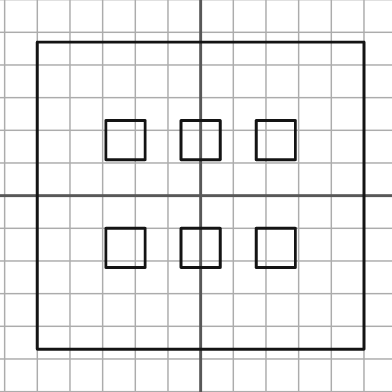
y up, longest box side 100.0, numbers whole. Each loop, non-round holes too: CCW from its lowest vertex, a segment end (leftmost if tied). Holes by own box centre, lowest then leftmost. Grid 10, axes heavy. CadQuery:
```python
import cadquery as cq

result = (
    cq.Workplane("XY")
    .moveTo(-50.0, -47.0)
    .lineTo(50.0, -47.0)
    .lineTo(50.0, 47.0)
    .lineTo(-50.0, 47.0)
    .close()
    .moveTo(-29.0, -22.0)
    .lineTo(-17.0, -22.0)
    .lineTo(-17.0, -10.0)
    .lineTo(-29.0, -10.0)
    .close()
    .moveTo(-6.0, -22.0)
    .lineTo(6.0, -22.0)
    .lineTo(6.0, -10.0)
    .lineTo(-6.0, -10.0)
    .close()
    .moveTo(17.0, -22.0)
    .lineTo(29.0, -22.0)
    .lineTo(29.0, -10.0)
    .lineTo(17.0, -10.0)
    .close()
    .moveTo(-29.0, 11.0)
    .lineTo(-17.0, 11.0)
    .lineTo(-17.0, 23.0)
    .lineTo(-29.0, 23.0)
    .close()
    .moveTo(-6.0, 11.0)
    .lineTo(6.0, 11.0)
    .lineTo(6.0, 23.0)
    .lineTo(-6.0, 23.0)
    .close()
    .moveTo(17.0, 11.0)
    .lineTo(29.0, 11.0)
    .lineTo(29.0, 23.0)
    .lineTo(17.0, 23.0)
    .close()
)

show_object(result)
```